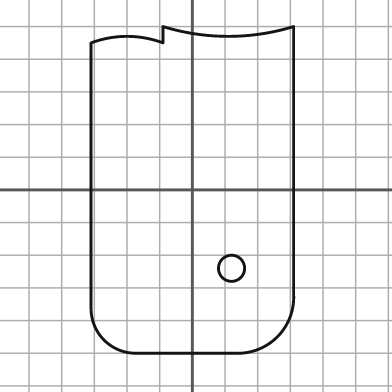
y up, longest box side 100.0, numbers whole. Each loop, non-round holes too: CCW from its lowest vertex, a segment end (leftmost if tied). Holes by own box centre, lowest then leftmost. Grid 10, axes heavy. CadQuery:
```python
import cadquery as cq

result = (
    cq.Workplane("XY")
    .moveTo(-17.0, -50.0)
    .lineTo(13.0, -50.0)
    .threePointArc((26.0, -45.0), (31.0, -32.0))
    .lineTo(31.0, 50.0)
    .threePointArc((11.0, 47.0), (-9.0, 50.0))
    .lineTo(-9.0, 45.0)
    .threePointArc((-20.0, 47.0), (-31.0, 45.0))
    .lineTo(-31.0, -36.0)
    .threePointArc((-27.0, -46.0), (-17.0, -50.0))
    .close()
    .moveTo(12.0, -24.0)
    .circle(4.0)
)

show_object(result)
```